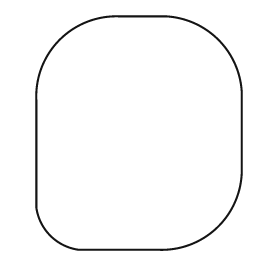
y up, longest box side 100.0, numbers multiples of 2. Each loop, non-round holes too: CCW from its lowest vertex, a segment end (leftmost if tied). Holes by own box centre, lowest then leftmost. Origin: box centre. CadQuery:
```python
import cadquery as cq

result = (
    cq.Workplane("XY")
    .moveTo(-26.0, -50.0)
    .lineTo(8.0, -50.0)
    .threePointArc((34.0, -40.0), (44.0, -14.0))
    .lineTo(44.0, 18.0)
    .threePointArc((34.0, 40.0), (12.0, 50.0))
    .lineTo(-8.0, 50.0)
    .threePointArc((-34.0, 40.0), (-44.0, 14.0))
    .lineTo(-44.0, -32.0)
    .threePointArc((-38.0, -44.0), (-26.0, -50.0))
    .close()
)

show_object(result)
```